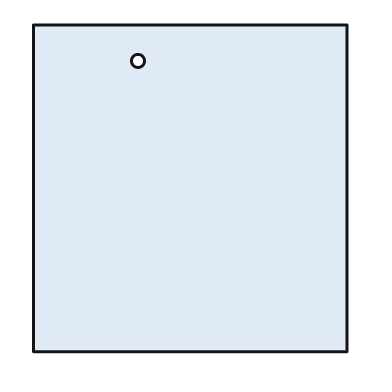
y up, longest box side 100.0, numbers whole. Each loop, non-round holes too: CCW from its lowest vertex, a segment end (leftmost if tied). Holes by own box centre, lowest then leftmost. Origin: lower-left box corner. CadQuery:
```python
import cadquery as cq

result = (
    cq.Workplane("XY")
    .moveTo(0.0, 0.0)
    .lineTo(96.0, 0.0)
    .lineTo(96.0, 100.0)
    .lineTo(0.0, 100.0)
    .close()
    .moveTo(32.0, 89.0)
    .circle(2.0)
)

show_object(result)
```